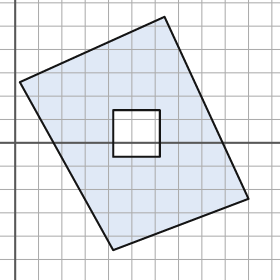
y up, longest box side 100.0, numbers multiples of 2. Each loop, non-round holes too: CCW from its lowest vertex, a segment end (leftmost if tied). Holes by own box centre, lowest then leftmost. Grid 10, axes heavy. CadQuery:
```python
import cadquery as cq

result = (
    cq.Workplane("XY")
    .moveTo(42.0, -46.0)
    .lineTo(100.0, -24.0)
    .lineTo(64.0, 54.0)
    .lineTo(2.0, 26.0)
    .close()
    .moveTo(42.0, -6.0)
    .lineTo(62.0, -6.0)
    .lineTo(62.0, 14.0)
    .lineTo(42.0, 14.0)
    .close()
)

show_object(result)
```